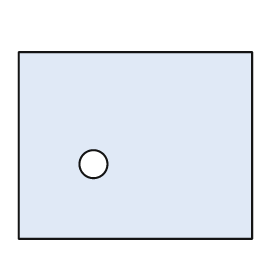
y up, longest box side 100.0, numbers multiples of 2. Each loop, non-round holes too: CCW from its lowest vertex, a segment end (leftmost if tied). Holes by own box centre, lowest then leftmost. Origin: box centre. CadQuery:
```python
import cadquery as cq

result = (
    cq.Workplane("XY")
    .moveTo(-50.0, -40.0)
    .lineTo(50.0, -40.0)
    .lineTo(50.0, 40.0)
    .lineTo(-50.0, 40.0)
    .close()
    .moveTo(-18.0, -8.0)
    .circle(6.0)
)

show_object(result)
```